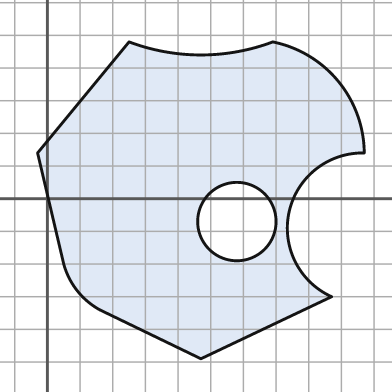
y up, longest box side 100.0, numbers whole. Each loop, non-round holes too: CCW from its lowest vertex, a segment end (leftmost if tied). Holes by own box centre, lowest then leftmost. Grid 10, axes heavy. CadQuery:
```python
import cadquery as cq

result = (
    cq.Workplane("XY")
    .moveTo(47.0, -49.0)
    .lineTo(87.0, -30.0)
    .threePointArc((74.0, -4.0), (97.0, 14.0))
    .threePointArc((89.0, 36.0), (69.0, 48.0))
    .threePointArc((47.0, 44.0), (25.0, 48.0))
    .lineTo(-3.0, 14.0)
    .lineTo(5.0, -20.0)
    .threePointArc((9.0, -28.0), (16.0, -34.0))
    .close()
    .moveTo(58.0, -7.0)
    .circle(12.0)
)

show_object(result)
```